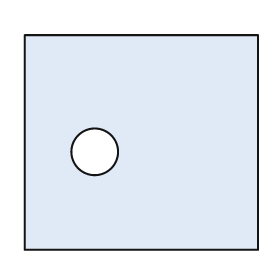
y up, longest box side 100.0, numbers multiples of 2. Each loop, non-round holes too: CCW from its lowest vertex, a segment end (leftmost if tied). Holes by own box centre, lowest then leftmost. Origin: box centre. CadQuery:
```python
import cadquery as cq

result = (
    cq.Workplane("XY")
    .moveTo(-50.0, -46.0)
    .lineTo(50.0, -46.0)
    .lineTo(50.0, 46.0)
    .lineTo(-50.0, 46.0)
    .close()
    .moveTo(-20.0, -4.0)
    .circle(10.0)
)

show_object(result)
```